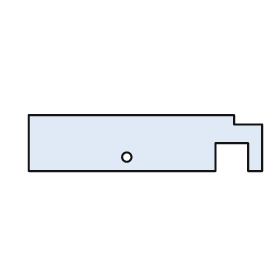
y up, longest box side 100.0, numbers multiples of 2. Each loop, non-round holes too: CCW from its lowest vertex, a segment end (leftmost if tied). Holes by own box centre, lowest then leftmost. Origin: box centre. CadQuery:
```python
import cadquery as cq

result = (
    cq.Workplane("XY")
    .moveTo(-50.0, -12.0)
    .lineTo(30.0, -12.0)
    .lineTo(30.0, 0.0)
    .lineTo(44.0, 0.0)
    .lineTo(44.0, -12.0)
    .lineTo(50.0, -12.0)
    .lineTo(50.0, 8.0)
    .lineTo(38.0, 8.0)
    .lineTo(38.0, 12.0)
    .lineTo(-50.0, 12.0)
    .close()
    .moveTo(-8.0, -6.0)
    .circle(2.0)
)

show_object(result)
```